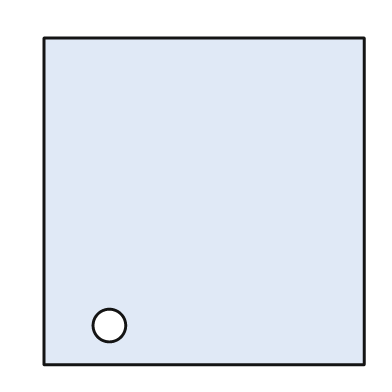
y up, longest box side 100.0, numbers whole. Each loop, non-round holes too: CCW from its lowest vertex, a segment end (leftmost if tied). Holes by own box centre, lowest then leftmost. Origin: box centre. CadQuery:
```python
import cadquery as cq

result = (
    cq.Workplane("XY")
    .moveTo(-49.0, -50.0)
    .lineTo(49.0, -50.0)
    .lineTo(49.0, 50.0)
    .lineTo(-49.0, 50.0)
    .close()
    .moveTo(-29.0, -38.0)
    .circle(5.0)
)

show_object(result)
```